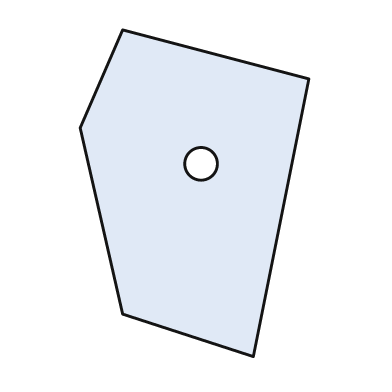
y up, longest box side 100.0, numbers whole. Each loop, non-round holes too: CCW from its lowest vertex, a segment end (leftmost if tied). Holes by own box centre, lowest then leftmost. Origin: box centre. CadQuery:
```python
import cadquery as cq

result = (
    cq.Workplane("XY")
    .moveTo(18.0, -50.0)
    .lineTo(35.0, 35.0)
    .lineTo(-22.0, 50.0)
    .lineTo(-35.0, 20.0)
    .lineTo(-22.0, -37.0)
    .close()
    .moveTo(2.0, 9.0)
    .circle(5.0)
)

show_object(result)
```